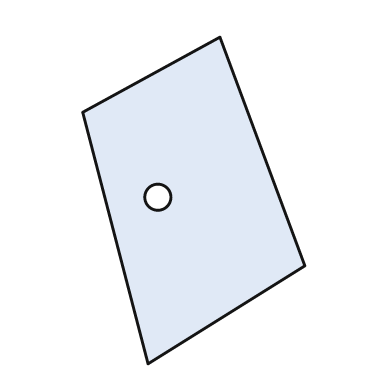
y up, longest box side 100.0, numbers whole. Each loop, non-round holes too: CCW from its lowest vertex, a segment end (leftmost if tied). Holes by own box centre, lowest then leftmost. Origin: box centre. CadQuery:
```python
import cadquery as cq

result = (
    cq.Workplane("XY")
    .moveTo(-14.0, -50.0)
    .lineTo(34.0, -20.0)
    .lineTo(8.0, 50.0)
    .lineTo(-34.0, 27.0)
    .close()
    .moveTo(-11.0, 1.0)
    .circle(4.0)
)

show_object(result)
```